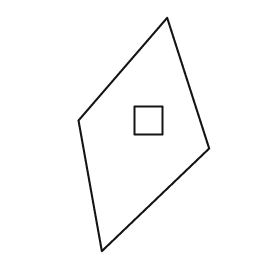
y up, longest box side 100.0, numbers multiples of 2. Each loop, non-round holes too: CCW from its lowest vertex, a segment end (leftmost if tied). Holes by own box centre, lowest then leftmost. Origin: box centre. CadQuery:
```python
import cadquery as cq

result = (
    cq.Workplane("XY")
    .moveTo(-18.0, -50.0)
    .lineTo(28.0, -6.0)
    .lineTo(10.0, 50.0)
    .lineTo(-28.0, 6.0)
    .close()
    .moveTo(-4.0, 0.0)
    .lineTo(8.0, 0.0)
    .lineTo(8.0, 12.0)
    .lineTo(-4.0, 12.0)
    .close()
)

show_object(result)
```